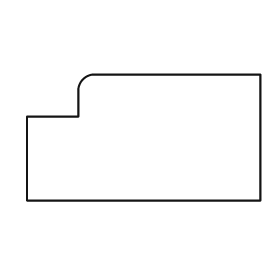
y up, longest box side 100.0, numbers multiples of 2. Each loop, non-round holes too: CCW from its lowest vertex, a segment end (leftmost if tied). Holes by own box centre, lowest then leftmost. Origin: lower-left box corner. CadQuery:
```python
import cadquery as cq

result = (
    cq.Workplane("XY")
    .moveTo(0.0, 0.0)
    .lineTo(100.0, 0.0)
    .lineTo(100.0, 54.0)
    .lineTo(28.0, 54.0)
    .threePointArc((24.0, 52.0), (22.0, 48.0))
    .lineTo(22.0, 36.0)
    .lineTo(0.0, 36.0)
    .close()
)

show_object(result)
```